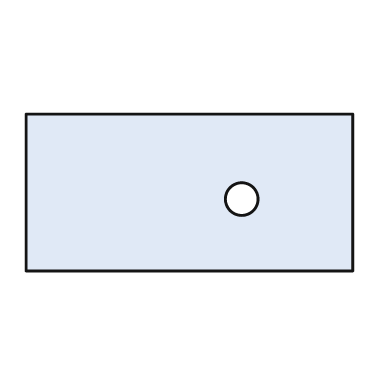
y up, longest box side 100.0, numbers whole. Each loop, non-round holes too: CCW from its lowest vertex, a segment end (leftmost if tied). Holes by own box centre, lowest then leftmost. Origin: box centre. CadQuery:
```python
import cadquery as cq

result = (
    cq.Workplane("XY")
    .moveTo(-50.0, -24.0)
    .lineTo(50.0, -24.0)
    .lineTo(50.0, 24.0)
    .lineTo(-50.0, 24.0)
    .close()
    .moveTo(16.0, -2.0)
    .circle(5.0)
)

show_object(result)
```